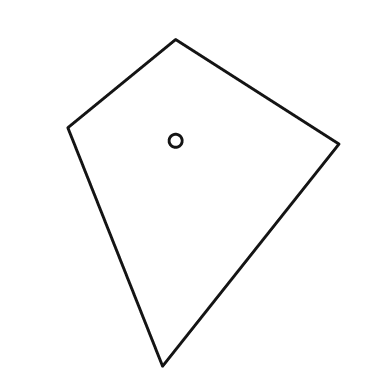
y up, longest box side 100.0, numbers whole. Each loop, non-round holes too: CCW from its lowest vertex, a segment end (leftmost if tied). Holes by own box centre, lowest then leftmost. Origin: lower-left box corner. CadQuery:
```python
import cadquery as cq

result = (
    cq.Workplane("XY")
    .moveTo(29.0, 0.0)
    .lineTo(83.0, 68.0)
    .lineTo(33.0, 100.0)
    .lineTo(0.0, 73.0)
    .close()
    .moveTo(33.0, 69.0)
    .circle(2.0)
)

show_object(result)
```